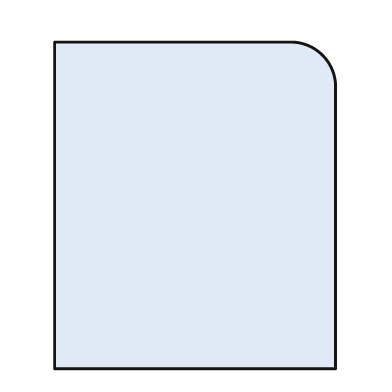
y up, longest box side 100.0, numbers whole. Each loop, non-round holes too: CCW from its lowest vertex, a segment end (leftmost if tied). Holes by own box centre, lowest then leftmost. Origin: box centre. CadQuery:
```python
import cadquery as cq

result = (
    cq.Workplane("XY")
    .moveTo(-43.0, -50.0)
    .lineTo(43.0, -50.0)
    .lineTo(43.0, 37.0)
    .threePointArc((39.0, 46.0), (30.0, 50.0))
    .lineTo(-43.0, 50.0)
    .close()
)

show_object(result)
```